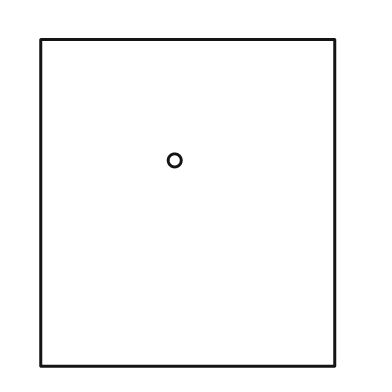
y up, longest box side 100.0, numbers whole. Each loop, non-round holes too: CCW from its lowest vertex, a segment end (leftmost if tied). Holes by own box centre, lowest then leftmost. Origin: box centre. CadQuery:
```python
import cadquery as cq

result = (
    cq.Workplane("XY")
    .moveTo(-45.0, -50.0)
    .lineTo(45.0, -50.0)
    .lineTo(45.0, 50.0)
    .lineTo(-45.0, 50.0)
    .close()
    .moveTo(-4.0, 13.0)
    .circle(2.0)
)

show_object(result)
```